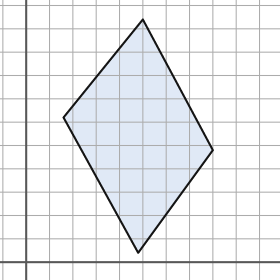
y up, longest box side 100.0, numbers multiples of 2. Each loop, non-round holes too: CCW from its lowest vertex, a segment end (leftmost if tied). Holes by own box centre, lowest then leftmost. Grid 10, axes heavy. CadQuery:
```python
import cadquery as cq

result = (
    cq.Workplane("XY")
    .moveTo(48.0, 4.0)
    .lineTo(80.0, 48.0)
    .lineTo(50.0, 104.0)
    .lineTo(16.0, 62.0)
    .close()
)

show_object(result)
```